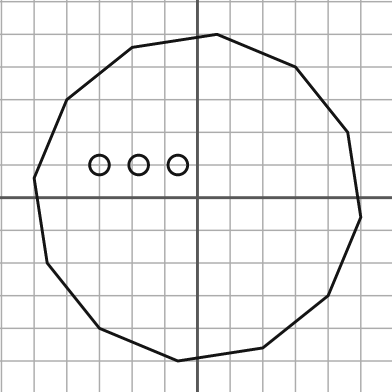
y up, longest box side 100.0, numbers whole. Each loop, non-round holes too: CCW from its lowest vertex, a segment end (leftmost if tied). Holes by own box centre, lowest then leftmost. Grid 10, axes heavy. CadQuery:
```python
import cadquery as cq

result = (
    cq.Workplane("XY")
    .moveTo(-6.0, -50.0)
    .lineTo(20.0, -46.0)
    .lineTo(40.0, -30.0)
    .lineTo(50.0, -6.0)
    .lineTo(46.0, 20.0)
    .lineTo(30.0, 40.0)
    .lineTo(6.0, 50.0)
    .lineTo(-20.0, 46.0)
    .lineTo(-40.0, 30.0)
    .lineTo(-50.0, 6.0)
    .lineTo(-46.0, -20.0)
    .lineTo(-30.0, -40.0)
    .close()
    .moveTo(-30.0, 10.0)
    .circle(3.0)
    .moveTo(-18.0, 10.0)
    .circle(3.0)
    .moveTo(-6.0, 10.0)
    .circle(3.0)
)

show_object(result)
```